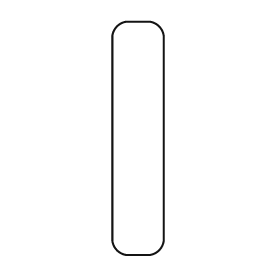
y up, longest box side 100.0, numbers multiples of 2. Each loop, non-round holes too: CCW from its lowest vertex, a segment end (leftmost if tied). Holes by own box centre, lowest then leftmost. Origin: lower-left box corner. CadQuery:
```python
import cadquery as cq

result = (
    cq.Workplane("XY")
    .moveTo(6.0, 0.0)
    .lineTo(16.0, 0.0)
    .threePointArc((20.0, 2.0), (22.0, 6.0))
    .lineTo(22.0, 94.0)
    .threePointArc((20.0, 98.0), (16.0, 100.0))
    .lineTo(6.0, 100.0)
    .threePointArc((2.0, 98.0), (0.0, 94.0))
    .lineTo(0.0, 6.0)
    .threePointArc((2.0, 2.0), (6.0, 0.0))
    .close()
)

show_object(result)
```